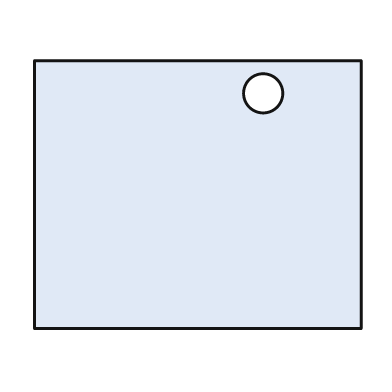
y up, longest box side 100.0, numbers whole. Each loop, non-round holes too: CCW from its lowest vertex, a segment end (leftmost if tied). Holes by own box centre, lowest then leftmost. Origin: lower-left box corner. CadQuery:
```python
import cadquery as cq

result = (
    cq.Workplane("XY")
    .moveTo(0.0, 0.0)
    .lineTo(100.0, 0.0)
    .lineTo(100.0, 82.0)
    .lineTo(0.0, 82.0)
    .close()
    .moveTo(70.0, 72.0)
    .circle(6.0)
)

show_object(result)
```